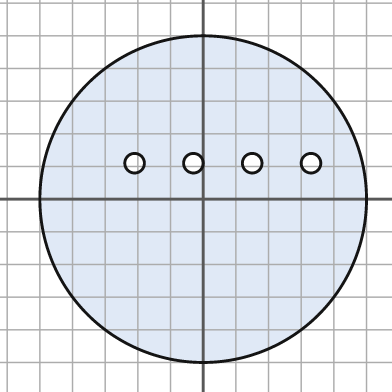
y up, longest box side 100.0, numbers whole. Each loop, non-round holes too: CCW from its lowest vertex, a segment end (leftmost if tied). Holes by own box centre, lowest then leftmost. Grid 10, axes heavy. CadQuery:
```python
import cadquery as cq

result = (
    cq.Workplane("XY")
    .moveTo(0.0, 0.0)
    .circle(50.0)
    .moveTo(-21.0, 11.0)
    .circle(3.0)
    .moveTo(-3.0, 11.0)
    .circle(3.0)
    .moveTo(15.0, 11.0)
    .circle(3.0)
    .moveTo(33.0, 11.0)
    .circle(3.0)
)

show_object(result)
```